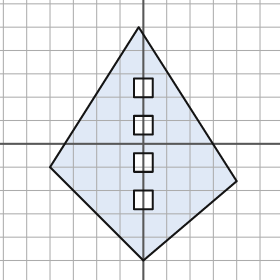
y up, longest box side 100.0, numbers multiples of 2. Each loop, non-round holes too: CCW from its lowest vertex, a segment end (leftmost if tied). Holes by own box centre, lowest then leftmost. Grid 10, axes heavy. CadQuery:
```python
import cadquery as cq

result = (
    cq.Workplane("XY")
    .moveTo(0.0, -50.0)
    .lineTo(40.0, -16.0)
    .lineTo(-2.0, 50.0)
    .lineTo(-40.0, -10.0)
    .close()
    .moveTo(-4.0, -28.0)
    .lineTo(4.0, -28.0)
    .lineTo(4.0, -20.0)
    .lineTo(-4.0, -20.0)
    .close()
    .moveTo(-4.0, -12.0)
    .lineTo(4.0, -12.0)
    .lineTo(4.0, -4.0)
    .lineTo(-4.0, -4.0)
    .close()
    .moveTo(-4.0, 4.0)
    .lineTo(4.0, 4.0)
    .lineTo(4.0, 12.0)
    .lineTo(-4.0, 12.0)
    .close()
    .moveTo(-4.0, 20.0)
    .lineTo(4.0, 20.0)
    .lineTo(4.0, 28.0)
    .lineTo(-4.0, 28.0)
    .close()
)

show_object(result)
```